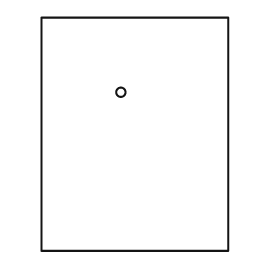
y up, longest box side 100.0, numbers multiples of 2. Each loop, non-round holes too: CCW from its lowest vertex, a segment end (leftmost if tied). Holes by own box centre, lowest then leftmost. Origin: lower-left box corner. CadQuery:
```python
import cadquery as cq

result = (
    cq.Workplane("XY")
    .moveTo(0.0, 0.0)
    .lineTo(80.0, 0.0)
    .lineTo(80.0, 100.0)
    .lineTo(0.0, 100.0)
    .close()
    .moveTo(34.0, 68.0)
    .circle(2.0)
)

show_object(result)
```